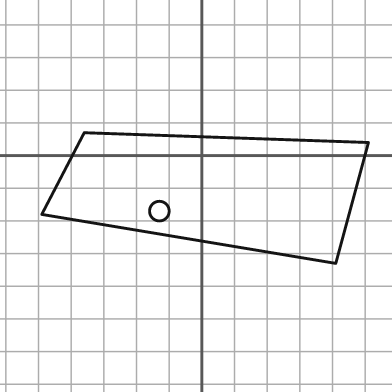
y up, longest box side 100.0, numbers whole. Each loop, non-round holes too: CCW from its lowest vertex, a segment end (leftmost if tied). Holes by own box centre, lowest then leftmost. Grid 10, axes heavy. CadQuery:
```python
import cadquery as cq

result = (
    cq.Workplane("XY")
    .moveTo(41.0, -33.0)
    .lineTo(51.0, 4.0)
    .lineTo(-36.0, 7.0)
    .lineTo(-49.0, -18.0)
    .close()
    .moveTo(-13.0, -17.0)
    .circle(3.0)
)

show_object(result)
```